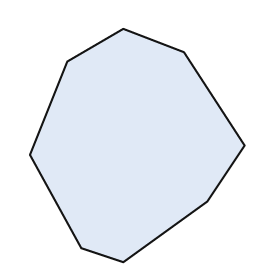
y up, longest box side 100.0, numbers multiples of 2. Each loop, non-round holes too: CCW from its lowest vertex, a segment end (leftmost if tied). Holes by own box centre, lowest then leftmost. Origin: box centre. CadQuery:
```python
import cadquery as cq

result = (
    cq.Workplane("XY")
    .moveTo(-6.0, -50.0)
    .lineTo(30.0, -24.0)
    .lineTo(46.0, 0.0)
    .lineTo(20.0, 40.0)
    .lineTo(-6.0, 50.0)
    .lineTo(-30.0, 36.0)
    .lineTo(-46.0, -4.0)
    .lineTo(-24.0, -44.0)
    .close()
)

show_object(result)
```